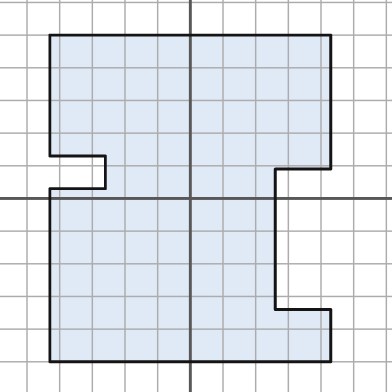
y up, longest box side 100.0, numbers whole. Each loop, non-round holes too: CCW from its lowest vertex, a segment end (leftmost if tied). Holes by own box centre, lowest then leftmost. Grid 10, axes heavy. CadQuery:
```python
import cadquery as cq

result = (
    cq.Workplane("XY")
    .moveTo(-43.0, -50.0)
    .lineTo(43.0, -50.0)
    .lineTo(43.0, -34.0)
    .lineTo(26.0, -34.0)
    .lineTo(26.0, 9.0)
    .lineTo(43.0, 9.0)
    .lineTo(43.0, 50.0)
    .lineTo(-43.0, 50.0)
    .lineTo(-43.0, 13.0)
    .lineTo(-26.0, 13.0)
    .lineTo(-26.0, 3.0)
    .lineTo(-43.0, 3.0)
    .close()
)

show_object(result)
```